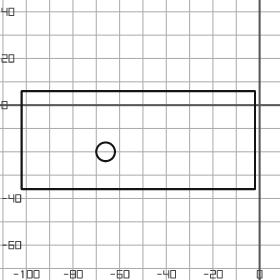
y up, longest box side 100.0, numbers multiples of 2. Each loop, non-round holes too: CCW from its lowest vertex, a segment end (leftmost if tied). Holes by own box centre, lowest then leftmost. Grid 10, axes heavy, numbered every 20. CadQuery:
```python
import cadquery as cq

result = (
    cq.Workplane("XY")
    .moveTo(-102.0, -36.0)
    .lineTo(-2.0, -36.0)
    .lineTo(-2.0, 6.0)
    .lineTo(-102.0, 6.0)
    .close()
    .moveTo(-66.0, -20.0)
    .circle(4.0)
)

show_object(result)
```